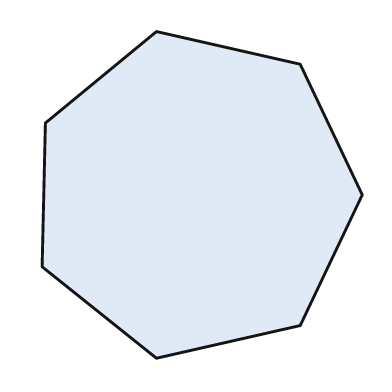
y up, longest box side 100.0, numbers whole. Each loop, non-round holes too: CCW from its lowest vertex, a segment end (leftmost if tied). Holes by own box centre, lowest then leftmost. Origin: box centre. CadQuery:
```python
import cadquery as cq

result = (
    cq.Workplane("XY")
    .moveTo(-14.0, -50.0)
    .lineTo(30.0, -40.0)
    .lineTo(49.0, 0.0)
    .lineTo(30.0, 40.0)
    .lineTo(-14.0, 50.0)
    .lineTo(-48.0, 22.0)
    .lineTo(-49.0, -22.0)
    .close()
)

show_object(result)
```